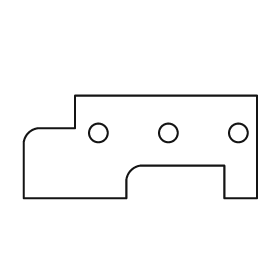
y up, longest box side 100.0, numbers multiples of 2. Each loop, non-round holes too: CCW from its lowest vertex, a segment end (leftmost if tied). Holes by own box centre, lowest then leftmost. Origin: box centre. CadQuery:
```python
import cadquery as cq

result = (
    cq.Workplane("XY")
    .moveTo(-50.0, -22.0)
    .lineTo(-6.0, -22.0)
    .lineTo(-6.0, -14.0)
    .threePointArc((-4.0, -10.0), (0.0, -8.0))
    .lineTo(36.0, -8.0)
    .lineTo(36.0, -22.0)
    .lineTo(50.0, -22.0)
    .lineTo(50.0, 22.0)
    .lineTo(-28.0, 22.0)
    .lineTo(-28.0, 8.0)
    .lineTo(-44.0, 8.0)
    .threePointArc((-48.0, 6.0), (-50.0, 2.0))
    .close()
    .moveTo(-18.0, 6.0)
    .circle(4.0)
    .moveTo(12.0, 6.0)
    .circle(4.0)
    .moveTo(42.0, 6.0)
    .circle(4.0)
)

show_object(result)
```